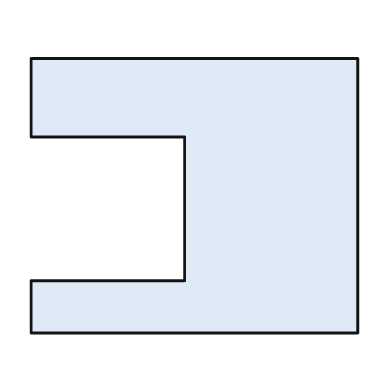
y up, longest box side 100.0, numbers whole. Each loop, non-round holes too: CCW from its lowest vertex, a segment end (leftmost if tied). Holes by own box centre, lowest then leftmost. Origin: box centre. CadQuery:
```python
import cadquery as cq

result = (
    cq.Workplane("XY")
    .moveTo(-50.0, -42.0)
    .lineTo(50.0, -42.0)
    .lineTo(50.0, 42.0)
    .lineTo(-50.0, 42.0)
    .lineTo(-50.0, 18.0)
    .lineTo(-3.0, 18.0)
    .lineTo(-3.0, -26.0)
    .lineTo(-50.0, -26.0)
    .close()
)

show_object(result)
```